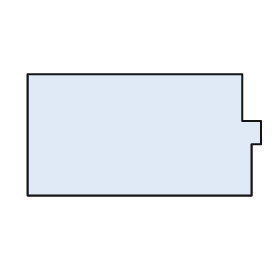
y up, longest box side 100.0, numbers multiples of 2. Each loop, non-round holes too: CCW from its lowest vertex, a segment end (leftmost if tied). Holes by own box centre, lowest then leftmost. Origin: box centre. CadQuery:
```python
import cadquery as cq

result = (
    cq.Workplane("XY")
    .moveTo(-50.0, -26.0)
    .lineTo(46.0, -26.0)
    .lineTo(46.0, -4.0)
    .lineTo(50.0, -4.0)
    .lineTo(50.0, 6.0)
    .lineTo(42.0, 6.0)
    .lineTo(42.0, 26.0)
    .lineTo(-50.0, 26.0)
    .close()
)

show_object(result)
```